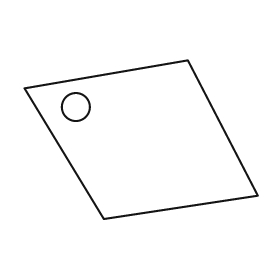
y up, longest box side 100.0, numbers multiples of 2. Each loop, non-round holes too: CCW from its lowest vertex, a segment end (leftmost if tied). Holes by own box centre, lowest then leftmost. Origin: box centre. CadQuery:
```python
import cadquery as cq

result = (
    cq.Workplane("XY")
    .moveTo(-16.0, -34.0)
    .lineTo(50.0, -24.0)
    .lineTo(20.0, 34.0)
    .lineTo(-50.0, 22.0)
    .close()
    .moveTo(-28.0, 14.0)
    .circle(6.0)
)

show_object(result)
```